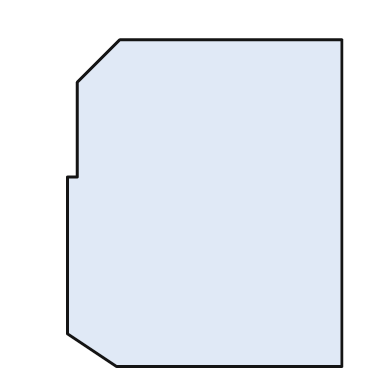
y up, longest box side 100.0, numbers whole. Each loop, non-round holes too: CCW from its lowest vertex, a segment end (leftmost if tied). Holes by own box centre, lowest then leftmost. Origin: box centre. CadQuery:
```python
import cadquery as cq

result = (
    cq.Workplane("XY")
    .moveTo(-27.0, -50.0)
    .lineTo(42.0, -50.0)
    .lineTo(42.0, 50.0)
    .lineTo(-26.0, 50.0)
    .lineTo(-39.0, 37.0)
    .lineTo(-39.0, 8.0)
    .lineTo(-42.0, 8.0)
    .lineTo(-42.0, -40.0)
    .close()
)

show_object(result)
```